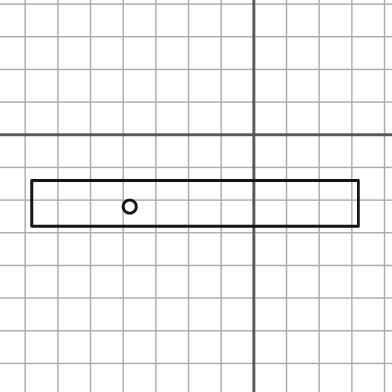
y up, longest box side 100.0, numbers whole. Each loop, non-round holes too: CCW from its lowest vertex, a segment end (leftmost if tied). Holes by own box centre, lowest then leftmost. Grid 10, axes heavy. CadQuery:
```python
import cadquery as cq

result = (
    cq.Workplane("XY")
    .moveTo(-68.0, -28.0)
    .lineTo(32.0, -28.0)
    .lineTo(32.0, -14.0)
    .lineTo(-68.0, -14.0)
    .close()
    .moveTo(-38.0, -22.0)
    .circle(2.0)
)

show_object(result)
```